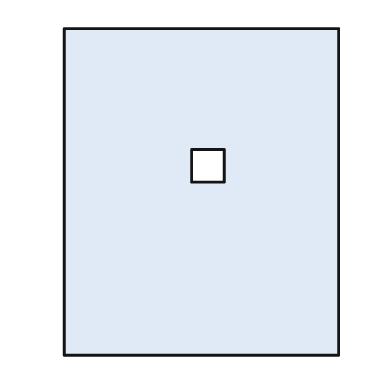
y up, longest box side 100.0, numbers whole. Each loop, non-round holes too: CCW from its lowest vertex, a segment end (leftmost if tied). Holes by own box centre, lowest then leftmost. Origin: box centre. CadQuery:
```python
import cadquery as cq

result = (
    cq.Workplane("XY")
    .moveTo(-42.0, -50.0)
    .lineTo(42.0, -50.0)
    .lineTo(42.0, 50.0)
    .lineTo(-42.0, 50.0)
    .close()
    .moveTo(-3.0, 3.0)
    .lineTo(7.0, 3.0)
    .lineTo(7.0, 13.0)
    .lineTo(-3.0, 13.0)
    .close()
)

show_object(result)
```